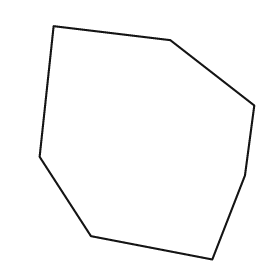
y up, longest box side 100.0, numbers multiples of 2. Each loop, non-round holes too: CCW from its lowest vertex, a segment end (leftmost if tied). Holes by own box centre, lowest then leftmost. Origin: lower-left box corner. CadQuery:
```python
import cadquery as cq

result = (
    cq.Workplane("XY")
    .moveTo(74.0, 0.0)
    .lineTo(88.0, 36.0)
    .lineTo(92.0, 66.0)
    .lineTo(56.0, 94.0)
    .lineTo(6.0, 100.0)
    .lineTo(0.0, 44.0)
    .lineTo(22.0, 10.0)
    .close()
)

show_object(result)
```